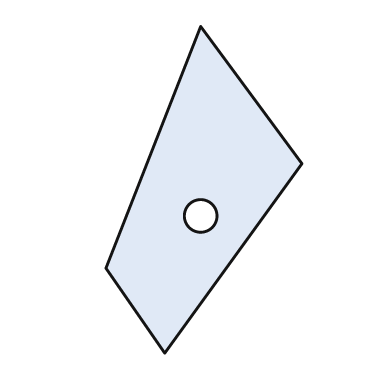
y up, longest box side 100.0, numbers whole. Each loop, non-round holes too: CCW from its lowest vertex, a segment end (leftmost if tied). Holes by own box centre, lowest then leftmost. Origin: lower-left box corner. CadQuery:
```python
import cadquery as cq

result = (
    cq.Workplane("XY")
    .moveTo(18.0, 0.0)
    .lineTo(60.0, 58.0)
    .lineTo(29.0, 100.0)
    .lineTo(0.0, 26.0)
    .close()
    .moveTo(29.0, 42.0)
    .circle(5.0)
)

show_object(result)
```